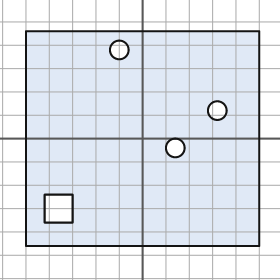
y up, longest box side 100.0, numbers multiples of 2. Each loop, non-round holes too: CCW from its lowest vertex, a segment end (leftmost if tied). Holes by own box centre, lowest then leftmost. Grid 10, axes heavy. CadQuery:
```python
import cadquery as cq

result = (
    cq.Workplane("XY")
    .moveTo(-50.0, -46.0)
    .lineTo(50.0, -46.0)
    .lineTo(50.0, 46.0)
    .lineTo(-50.0, 46.0)
    .close()
    .moveTo(-42.0, -36.0)
    .lineTo(-30.0, -36.0)
    .lineTo(-30.0, -24.0)
    .lineTo(-42.0, -24.0)
    .close()
    .moveTo(14.0, -4.0)
    .circle(4.0)
    .moveTo(32.0, 12.0)
    .circle(4.0)
    .moveTo(-10.0, 38.0)
    .circle(4.0)
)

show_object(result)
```